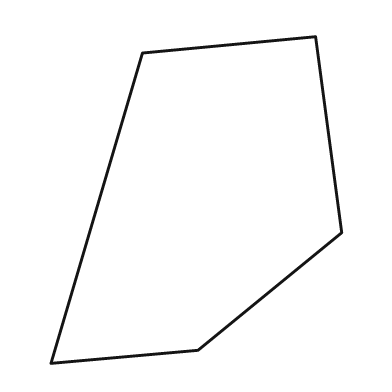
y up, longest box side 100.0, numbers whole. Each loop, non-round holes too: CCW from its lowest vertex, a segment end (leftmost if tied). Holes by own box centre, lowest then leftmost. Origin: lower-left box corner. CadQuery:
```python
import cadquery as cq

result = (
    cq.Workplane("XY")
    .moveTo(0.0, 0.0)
    .lineTo(45.0, 4.0)
    .lineTo(89.0, 40.0)
    .lineTo(81.0, 100.0)
    .lineTo(28.0, 95.0)
    .close()
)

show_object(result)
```